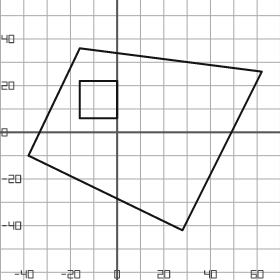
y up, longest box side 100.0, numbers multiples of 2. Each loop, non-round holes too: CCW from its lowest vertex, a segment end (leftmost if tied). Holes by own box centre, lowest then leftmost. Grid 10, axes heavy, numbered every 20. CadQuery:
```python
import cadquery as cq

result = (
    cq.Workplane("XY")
    .moveTo(28.0, -42.0)
    .lineTo(62.0, 26.0)
    .lineTo(-16.0, 36.0)
    .lineTo(-38.0, -10.0)
    .close()
    .moveTo(-16.0, 6.0)
    .lineTo(0.0, 6.0)
    .lineTo(0.0, 22.0)
    .lineTo(-16.0, 22.0)
    .close()
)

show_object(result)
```